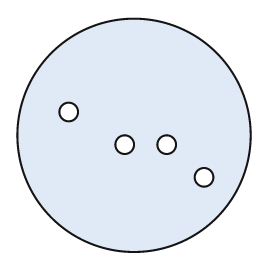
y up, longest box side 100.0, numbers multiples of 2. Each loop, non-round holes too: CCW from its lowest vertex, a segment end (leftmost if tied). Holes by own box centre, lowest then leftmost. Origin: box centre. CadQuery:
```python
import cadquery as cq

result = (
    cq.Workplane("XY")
    .moveTo(0.0, 0.0)
    .circle(50.0)
    .moveTo(30.0, -18.0)
    .circle(4.0)
    .moveTo(-4.0, -4.0)
    .circle(4.0)
    .moveTo(14.0, -4.0)
    .circle(4.0)
    .moveTo(-28.0, 10.0)
    .circle(4.0)
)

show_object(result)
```